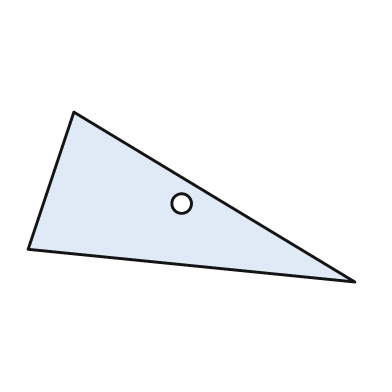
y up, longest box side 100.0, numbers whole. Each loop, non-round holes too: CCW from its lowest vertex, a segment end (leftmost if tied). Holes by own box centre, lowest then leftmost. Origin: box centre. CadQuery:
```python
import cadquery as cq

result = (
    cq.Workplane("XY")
    .moveTo(50.0, -26.0)
    .lineTo(-36.0, 26.0)
    .lineTo(-50.0, -16.0)
    .close()
    .moveTo(-3.0, -2.0)
    .circle(3.0)
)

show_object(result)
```